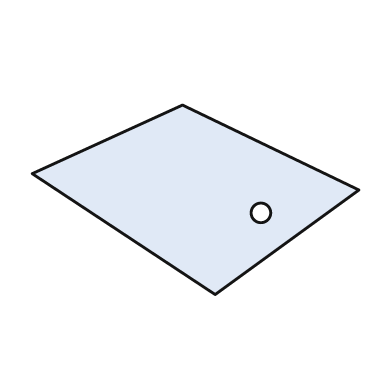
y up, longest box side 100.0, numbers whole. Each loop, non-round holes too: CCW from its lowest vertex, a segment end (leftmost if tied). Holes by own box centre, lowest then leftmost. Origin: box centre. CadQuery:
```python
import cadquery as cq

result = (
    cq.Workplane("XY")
    .moveTo(6.0, -29.0)
    .lineTo(50.0, 3.0)
    .lineTo(-4.0, 29.0)
    .lineTo(-50.0, 8.0)
    .close()
    .moveTo(20.0, -4.0)
    .circle(3.0)
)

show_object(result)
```